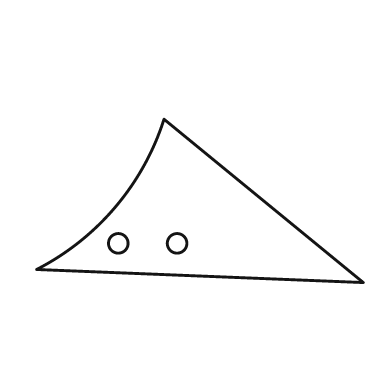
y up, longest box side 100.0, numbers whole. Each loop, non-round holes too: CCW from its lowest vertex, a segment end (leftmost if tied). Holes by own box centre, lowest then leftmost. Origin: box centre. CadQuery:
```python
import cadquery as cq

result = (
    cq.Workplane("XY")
    .moveTo(50.0, -25.0)
    .lineTo(-11.0, 25.0)
    .threePointArc((-26.0, -2.0), (-50.0, -21.0))
    .close()
    .moveTo(-25.0, -13.0)
    .circle(3.0)
    .moveTo(-7.0, -13.0)
    .circle(3.0)
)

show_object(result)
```